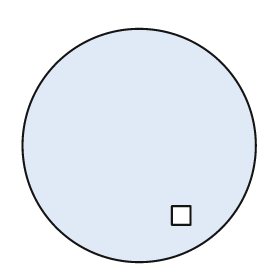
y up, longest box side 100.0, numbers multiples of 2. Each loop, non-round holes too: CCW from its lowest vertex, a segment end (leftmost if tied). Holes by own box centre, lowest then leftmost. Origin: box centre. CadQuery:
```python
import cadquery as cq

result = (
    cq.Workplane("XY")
    .moveTo(0.0, 0.0)
    .circle(50.0)
    .moveTo(14.0, -34.0)
    .lineTo(22.0, -34.0)
    .lineTo(22.0, -26.0)
    .lineTo(14.0, -26.0)
    .close()
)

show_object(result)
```